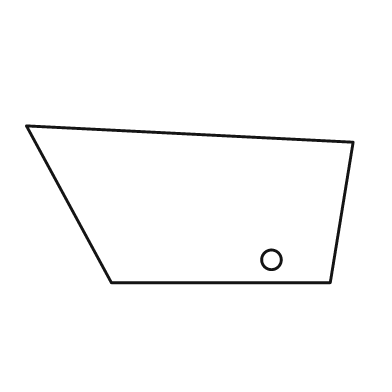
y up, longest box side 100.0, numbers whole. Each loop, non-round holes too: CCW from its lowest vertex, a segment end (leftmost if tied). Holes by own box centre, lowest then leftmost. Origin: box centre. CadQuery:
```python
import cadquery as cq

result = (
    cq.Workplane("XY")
    .moveTo(-24.0, -24.0)
    .lineTo(43.0, -24.0)
    .lineTo(50.0, 19.0)
    .lineTo(-50.0, 24.0)
    .close()
    .moveTo(25.0, -17.0)
    .circle(3.0)
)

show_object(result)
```